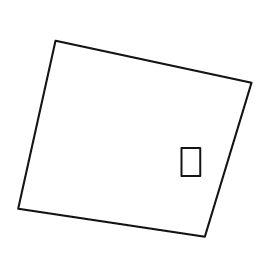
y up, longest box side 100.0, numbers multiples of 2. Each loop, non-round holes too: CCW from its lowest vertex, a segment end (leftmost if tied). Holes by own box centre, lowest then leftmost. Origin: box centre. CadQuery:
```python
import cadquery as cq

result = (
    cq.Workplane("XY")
    .moveTo(30.0, -42.0)
    .lineTo(50.0, 24.0)
    .lineTo(-34.0, 42.0)
    .lineTo(-50.0, -30.0)
    .close()
    .moveTo(20.0, -16.0)
    .lineTo(28.0, -16.0)
    .lineTo(28.0, -4.0)
    .lineTo(20.0, -4.0)
    .close()
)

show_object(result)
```